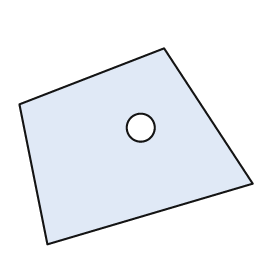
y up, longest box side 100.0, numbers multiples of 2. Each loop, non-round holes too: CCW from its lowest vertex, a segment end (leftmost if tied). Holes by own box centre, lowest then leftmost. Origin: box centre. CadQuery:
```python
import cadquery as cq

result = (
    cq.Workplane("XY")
    .moveTo(-38.0, -42.0)
    .lineTo(50.0, -16.0)
    .lineTo(12.0, 42.0)
    .lineTo(-50.0, 18.0)
    .close()
    .moveTo(2.0, 8.0)
    .circle(6.0)
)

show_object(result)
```